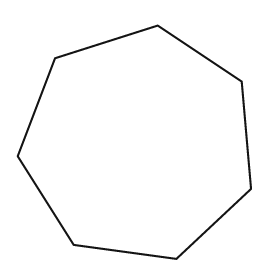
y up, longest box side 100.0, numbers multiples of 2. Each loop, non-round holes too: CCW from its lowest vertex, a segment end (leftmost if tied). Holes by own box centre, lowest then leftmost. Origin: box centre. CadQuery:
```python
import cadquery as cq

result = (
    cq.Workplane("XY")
    .moveTo(18.0, -50.0)
    .lineTo(50.0, -20.0)
    .lineTo(46.0, 26.0)
    .lineTo(10.0, 50.0)
    .lineTo(-34.0, 36.0)
    .lineTo(-50.0, -6.0)
    .lineTo(-26.0, -44.0)
    .close()
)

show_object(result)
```